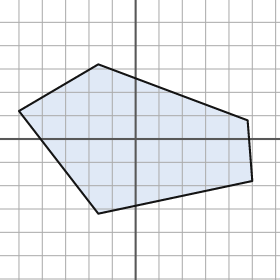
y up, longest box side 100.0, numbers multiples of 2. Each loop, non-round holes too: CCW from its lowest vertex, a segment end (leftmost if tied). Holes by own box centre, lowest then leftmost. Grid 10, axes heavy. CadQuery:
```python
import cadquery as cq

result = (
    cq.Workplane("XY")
    .moveTo(-16.0, -32.0)
    .lineTo(50.0, -18.0)
    .lineTo(48.0, 8.0)
    .lineTo(-16.0, 32.0)
    .lineTo(-50.0, 12.0)
    .close()
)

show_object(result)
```